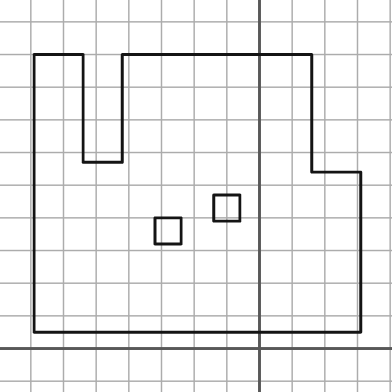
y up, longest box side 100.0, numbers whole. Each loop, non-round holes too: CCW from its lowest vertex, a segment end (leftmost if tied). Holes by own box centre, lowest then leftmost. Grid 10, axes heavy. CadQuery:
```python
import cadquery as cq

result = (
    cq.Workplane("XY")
    .moveTo(-69.0, 5.0)
    .lineTo(31.0, 5.0)
    .lineTo(31.0, 54.0)
    .lineTo(16.0, 54.0)
    .lineTo(16.0, 90.0)
    .lineTo(-42.0, 90.0)
    .lineTo(-42.0, 57.0)
    .lineTo(-54.0, 57.0)
    .lineTo(-54.0, 90.0)
    .lineTo(-69.0, 90.0)
    .close()
    .moveTo(-32.0, 32.0)
    .lineTo(-24.0, 32.0)
    .lineTo(-24.0, 40.0)
    .lineTo(-32.0, 40.0)
    .close()
    .moveTo(-14.0, 39.0)
    .lineTo(-6.0, 39.0)
    .lineTo(-6.0, 47.0)
    .lineTo(-14.0, 47.0)
    .close()
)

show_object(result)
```